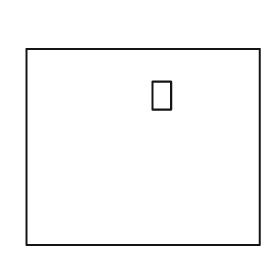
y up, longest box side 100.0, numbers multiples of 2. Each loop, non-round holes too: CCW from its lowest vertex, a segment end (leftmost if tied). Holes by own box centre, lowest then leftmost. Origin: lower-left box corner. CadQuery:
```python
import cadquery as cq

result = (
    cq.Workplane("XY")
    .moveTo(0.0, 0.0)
    .lineTo(100.0, 0.0)
    .lineTo(100.0, 84.0)
    .lineTo(0.0, 84.0)
    .close()
    .moveTo(54.0, 58.0)
    .lineTo(62.0, 58.0)
    .lineTo(62.0, 70.0)
    .lineTo(54.0, 70.0)
    .close()
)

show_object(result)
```